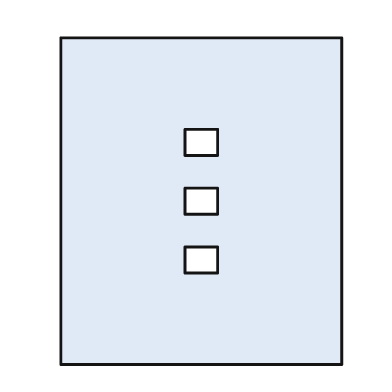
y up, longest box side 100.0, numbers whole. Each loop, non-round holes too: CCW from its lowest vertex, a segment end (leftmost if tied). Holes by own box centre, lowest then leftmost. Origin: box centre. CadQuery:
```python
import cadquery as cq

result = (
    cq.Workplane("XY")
    .moveTo(-43.0, -50.0)
    .lineTo(43.0, -50.0)
    .lineTo(43.0, 50.0)
    .lineTo(-43.0, 50.0)
    .close()
    .moveTo(-5.0, -22.0)
    .lineTo(5.0, -22.0)
    .lineTo(5.0, -14.0)
    .lineTo(-5.0, -14.0)
    .close()
    .moveTo(-5.0, -4.0)
    .lineTo(5.0, -4.0)
    .lineTo(5.0, 4.0)
    .lineTo(-5.0, 4.0)
    .close()
    .moveTo(-5.0, 14.0)
    .lineTo(5.0, 14.0)
    .lineTo(5.0, 22.0)
    .lineTo(-5.0, 22.0)
    .close()
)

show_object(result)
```